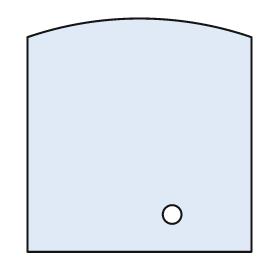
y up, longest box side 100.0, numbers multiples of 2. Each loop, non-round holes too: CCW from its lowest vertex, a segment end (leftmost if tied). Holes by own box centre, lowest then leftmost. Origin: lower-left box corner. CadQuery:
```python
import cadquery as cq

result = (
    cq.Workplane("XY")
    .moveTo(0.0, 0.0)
    .lineTo(96.0, 0.0)
    .lineTo(96.0, 92.0)
    .threePointArc((48.0, 100.0), (0.0, 92.0))
    .close()
    .moveTo(62.0, 16.0)
    .circle(4.0)
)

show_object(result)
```